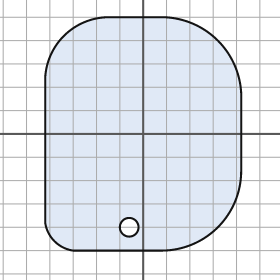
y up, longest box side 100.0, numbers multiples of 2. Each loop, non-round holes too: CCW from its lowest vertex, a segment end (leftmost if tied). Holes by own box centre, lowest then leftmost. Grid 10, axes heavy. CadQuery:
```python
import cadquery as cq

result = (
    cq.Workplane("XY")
    .moveTo(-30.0, -50.0)
    .lineTo(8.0, -50.0)
    .threePointArc((32.0, -40.0), (42.0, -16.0))
    .lineTo(42.0, 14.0)
    .threePointArc((32.0, 40.0), (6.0, 50.0))
    .lineTo(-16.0, 50.0)
    .threePointArc((-34.0, 42.0), (-42.0, 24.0))
    .lineTo(-42.0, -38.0)
    .threePointArc((-38.0, -46.0), (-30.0, -50.0))
    .close()
    .moveTo(-6.0, -40.0)
    .circle(4.0)
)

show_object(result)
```